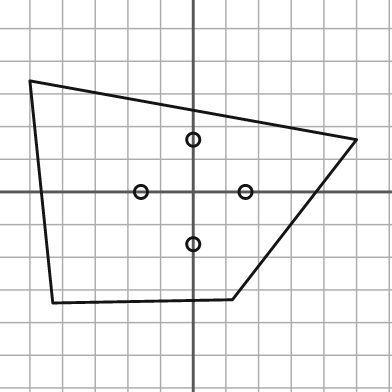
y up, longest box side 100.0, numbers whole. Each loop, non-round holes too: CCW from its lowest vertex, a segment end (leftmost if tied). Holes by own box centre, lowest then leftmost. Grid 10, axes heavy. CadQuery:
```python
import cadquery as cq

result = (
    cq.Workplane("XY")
    .moveTo(-43.0, -34.0)
    .lineTo(12.0, -33.0)
    .lineTo(50.0, 16.0)
    .lineTo(-50.0, 34.0)
    .close()
    .moveTo(0.0, -16.0)
    .circle(2.0)
    .moveTo(-16.0, 0.0)
    .circle(2.0)
    .moveTo(16.0, 0.0)
    .circle(2.0)
    .moveTo(0.0, 16.0)
    .circle(2.0)
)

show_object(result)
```